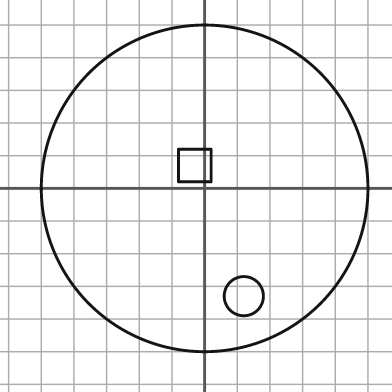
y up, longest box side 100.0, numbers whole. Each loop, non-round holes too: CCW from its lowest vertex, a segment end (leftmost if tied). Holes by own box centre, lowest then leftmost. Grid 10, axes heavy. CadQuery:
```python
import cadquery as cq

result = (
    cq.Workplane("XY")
    .moveTo(0.0, 0.0)
    .circle(50.0)
    .moveTo(12.0, -33.0)
    .circle(6.0)
    .moveTo(-8.0, 2.0)
    .lineTo(2.0, 2.0)
    .lineTo(2.0, 12.0)
    .lineTo(-8.0, 12.0)
    .close()
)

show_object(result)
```